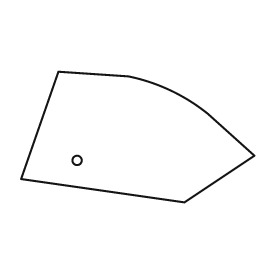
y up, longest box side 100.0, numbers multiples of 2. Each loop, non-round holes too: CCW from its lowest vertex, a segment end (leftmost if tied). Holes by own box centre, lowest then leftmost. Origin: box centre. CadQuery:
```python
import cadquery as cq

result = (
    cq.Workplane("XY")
    .moveTo(20.0, -28.0)
    .lineTo(50.0, -8.0)
    .lineTo(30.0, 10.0)
    .threePointArc((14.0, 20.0), (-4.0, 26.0))
    .lineTo(-34.0, 28.0)
    .lineTo(-50.0, -18.0)
    .close()
    .moveTo(-26.0, -10.0)
    .circle(2.0)
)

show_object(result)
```